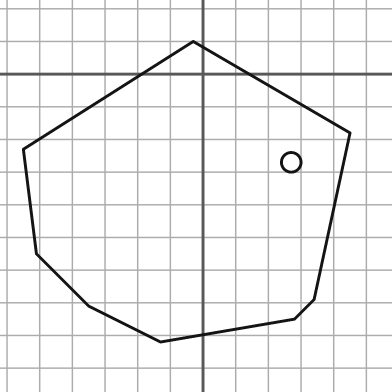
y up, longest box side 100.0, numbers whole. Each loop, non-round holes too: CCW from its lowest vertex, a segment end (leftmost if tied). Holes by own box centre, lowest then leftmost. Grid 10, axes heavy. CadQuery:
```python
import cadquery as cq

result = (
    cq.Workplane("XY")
    .moveTo(-13.0, -82.0)
    .lineTo(28.0, -75.0)
    .lineTo(34.0, -69.0)
    .lineTo(45.0, -18.0)
    .lineTo(-3.0, 10.0)
    .lineTo(-55.0, -23.0)
    .lineTo(-51.0, -55.0)
    .lineTo(-35.0, -71.0)
    .close()
    .moveTo(27.0, -27.0)
    .circle(3.0)
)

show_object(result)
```